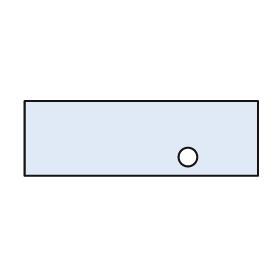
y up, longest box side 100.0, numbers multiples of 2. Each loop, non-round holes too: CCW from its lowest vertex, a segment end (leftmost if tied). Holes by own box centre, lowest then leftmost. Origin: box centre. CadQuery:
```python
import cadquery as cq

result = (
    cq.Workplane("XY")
    .moveTo(-50.0, -16.0)
    .lineTo(50.0, -16.0)
    .lineTo(50.0, 16.0)
    .lineTo(-50.0, 16.0)
    .close()
    .moveTo(20.0, -8.0)
    .circle(4.0)
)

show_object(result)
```